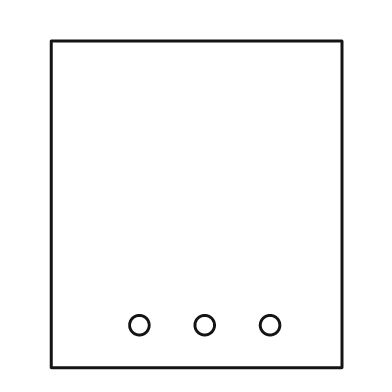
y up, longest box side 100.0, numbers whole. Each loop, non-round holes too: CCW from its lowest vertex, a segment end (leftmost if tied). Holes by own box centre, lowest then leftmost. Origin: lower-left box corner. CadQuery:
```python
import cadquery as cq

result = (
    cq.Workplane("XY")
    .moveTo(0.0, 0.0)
    .lineTo(89.0, 0.0)
    .lineTo(89.0, 100.0)
    .lineTo(0.0, 100.0)
    .close()
    .moveTo(27.0, 13.0)
    .circle(3.0)
    .moveTo(47.0, 13.0)
    .circle(3.0)
    .moveTo(67.0, 13.0)
    .circle(3.0)
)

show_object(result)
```